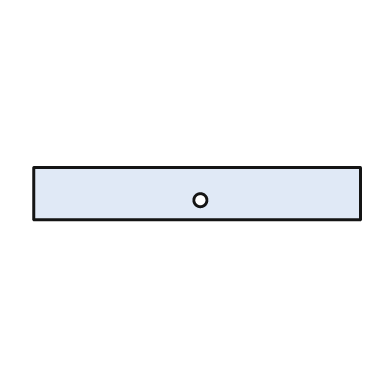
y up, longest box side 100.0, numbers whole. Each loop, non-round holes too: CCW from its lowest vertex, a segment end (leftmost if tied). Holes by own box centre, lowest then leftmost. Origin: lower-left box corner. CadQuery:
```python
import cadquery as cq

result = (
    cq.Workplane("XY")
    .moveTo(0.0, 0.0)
    .lineTo(100.0, 0.0)
    .lineTo(100.0, 16.0)
    .lineTo(0.0, 16.0)
    .close()
    .moveTo(51.0, 6.0)
    .circle(2.0)
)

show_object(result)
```